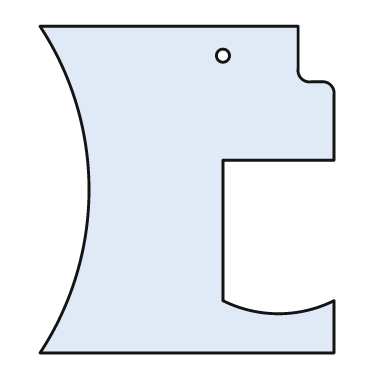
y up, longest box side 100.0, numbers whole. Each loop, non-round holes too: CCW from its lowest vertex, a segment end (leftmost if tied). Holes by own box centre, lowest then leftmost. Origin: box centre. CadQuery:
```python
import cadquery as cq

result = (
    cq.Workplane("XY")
    .moveTo(-45.0, -50.0)
    .lineTo(45.0, -50.0)
    .lineTo(45.0, -34.0)
    .threePointArc((28.0, -38.0), (11.0, -34.0))
    .lineTo(11.0, 9.0)
    .lineTo(45.0, 9.0)
    .lineTo(45.0, 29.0)
    .threePointArc((44.0, 32.0), (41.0, 33.0))
    .lineTo(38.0, 33.0)
    .threePointArc((35.0, 34.0), (34.0, 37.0))
    .lineTo(34.0, 50.0)
    .lineTo(-45.0, 50.0)
    .threePointArc((-30.0, 0.0), (-45.0, -50.0))
    .close()
    .moveTo(11.0, 41.0)
    .circle(2.0)
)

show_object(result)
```